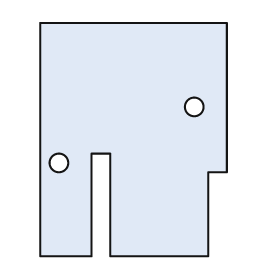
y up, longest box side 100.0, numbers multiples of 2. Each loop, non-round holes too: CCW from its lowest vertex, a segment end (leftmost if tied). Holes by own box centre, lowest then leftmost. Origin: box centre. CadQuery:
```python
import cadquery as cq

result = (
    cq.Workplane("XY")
    .moveTo(-40.0, -50.0)
    .lineTo(-18.0, -50.0)
    .lineTo(-18.0, -6.0)
    .lineTo(-10.0, -6.0)
    .lineTo(-10.0, -50.0)
    .lineTo(32.0, -50.0)
    .lineTo(32.0, -14.0)
    .lineTo(40.0, -14.0)
    .lineTo(40.0, 50.0)
    .lineTo(-40.0, 50.0)
    .close()
    .moveTo(-32.0, -10.0)
    .circle(4.0)
    .moveTo(26.0, 14.0)
    .circle(4.0)
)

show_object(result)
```